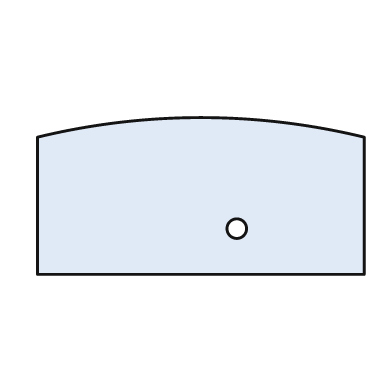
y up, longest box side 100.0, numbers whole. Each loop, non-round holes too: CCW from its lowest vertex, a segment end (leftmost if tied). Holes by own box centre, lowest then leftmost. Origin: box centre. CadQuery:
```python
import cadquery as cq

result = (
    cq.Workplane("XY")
    .moveTo(-50.0, -24.0)
    .lineTo(50.0, -24.0)
    .lineTo(50.0, 18.0)
    .threePointArc((0.0, 24.0), (-50.0, 18.0))
    .close()
    .moveTo(11.0, -10.0)
    .circle(3.0)
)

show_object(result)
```